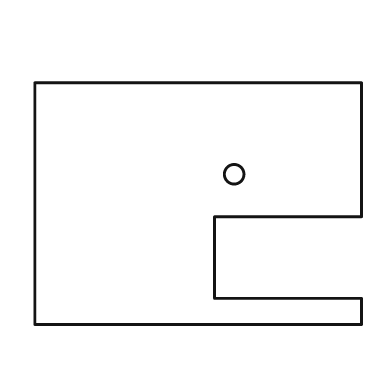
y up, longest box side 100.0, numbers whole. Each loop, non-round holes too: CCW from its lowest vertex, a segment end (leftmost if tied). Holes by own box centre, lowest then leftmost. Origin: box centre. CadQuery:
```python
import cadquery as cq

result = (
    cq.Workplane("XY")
    .moveTo(-50.0, -37.0)
    .lineTo(50.0, -37.0)
    .lineTo(50.0, -29.0)
    .lineTo(5.0, -29.0)
    .lineTo(5.0, -4.0)
    .lineTo(50.0, -4.0)
    .lineTo(50.0, 37.0)
    .lineTo(-50.0, 37.0)
    .close()
    .moveTo(11.0, 9.0)
    .circle(3.0)
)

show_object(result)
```